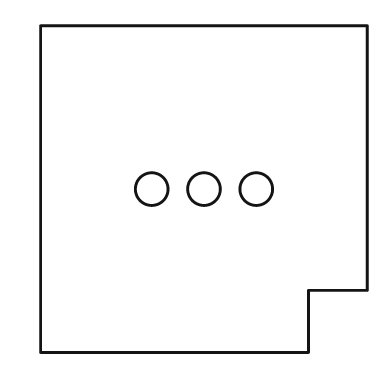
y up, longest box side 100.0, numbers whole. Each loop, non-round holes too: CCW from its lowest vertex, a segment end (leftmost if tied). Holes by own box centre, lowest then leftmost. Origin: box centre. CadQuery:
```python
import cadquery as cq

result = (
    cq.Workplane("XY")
    .moveTo(-50.0, -50.0)
    .lineTo(32.0, -50.0)
    .lineTo(32.0, -31.0)
    .lineTo(50.0, -31.0)
    .lineTo(50.0, 50.0)
    .lineTo(-50.0, 50.0)
    .close()
    .moveTo(-16.0, 0.0)
    .circle(5.0)
    .moveTo(0.0, 0.0)
    .circle(5.0)
    .moveTo(16.0, 0.0)
    .circle(5.0)
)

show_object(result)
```